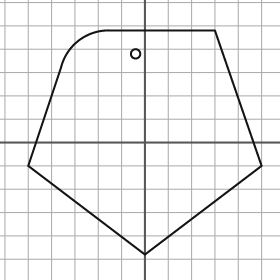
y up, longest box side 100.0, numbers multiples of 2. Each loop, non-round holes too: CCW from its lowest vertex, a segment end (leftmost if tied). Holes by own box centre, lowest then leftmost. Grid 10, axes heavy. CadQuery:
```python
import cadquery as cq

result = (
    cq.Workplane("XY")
    .moveTo(0.0, -48.0)
    .lineTo(50.0, -10.0)
    .lineTo(30.0, 48.0)
    .lineTo(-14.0, 48.0)
    .threePointArc((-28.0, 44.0), (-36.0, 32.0))
    .lineTo(-50.0, -10.0)
    .close()
    .moveTo(-4.0, 38.0)
    .circle(2.0)
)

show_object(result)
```